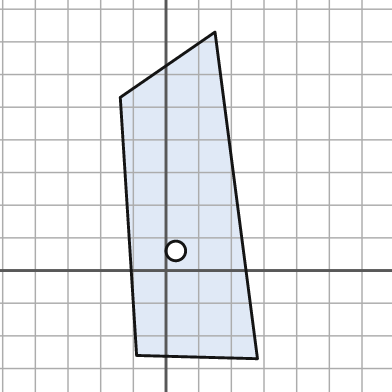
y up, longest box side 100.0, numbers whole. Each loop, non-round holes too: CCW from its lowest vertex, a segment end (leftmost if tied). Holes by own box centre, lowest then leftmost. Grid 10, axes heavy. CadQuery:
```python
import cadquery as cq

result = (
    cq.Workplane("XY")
    .moveTo(28.0, -27.0)
    .lineTo(15.0, 73.0)
    .lineTo(-14.0, 53.0)
    .lineTo(-9.0, -26.0)
    .close()
    .moveTo(3.0, 6.0)
    .circle(3.0)
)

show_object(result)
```